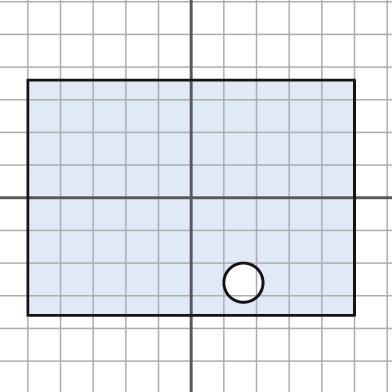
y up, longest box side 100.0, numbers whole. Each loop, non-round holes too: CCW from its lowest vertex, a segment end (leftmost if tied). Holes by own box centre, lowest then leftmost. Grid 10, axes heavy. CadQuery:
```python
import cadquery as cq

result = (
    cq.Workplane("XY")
    .moveTo(-50.0, -36.0)
    .lineTo(50.0, -36.0)
    .lineTo(50.0, 36.0)
    .lineTo(-50.0, 36.0)
    .close()
    .moveTo(16.0, -26.0)
    .circle(6.0)
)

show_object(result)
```